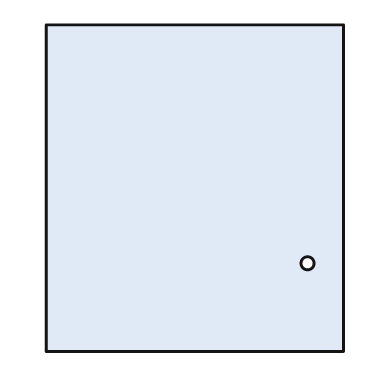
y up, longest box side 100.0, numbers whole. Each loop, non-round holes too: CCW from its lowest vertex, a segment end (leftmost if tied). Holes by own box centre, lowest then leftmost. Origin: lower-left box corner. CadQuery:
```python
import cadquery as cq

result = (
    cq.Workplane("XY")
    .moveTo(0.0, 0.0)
    .lineTo(91.0, 0.0)
    .lineTo(91.0, 100.0)
    .lineTo(0.0, 100.0)
    .close()
    .moveTo(80.0, 27.0)
    .circle(2.0)
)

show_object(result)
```